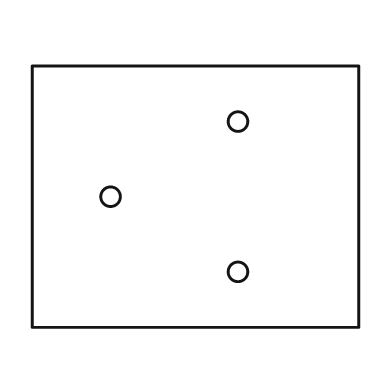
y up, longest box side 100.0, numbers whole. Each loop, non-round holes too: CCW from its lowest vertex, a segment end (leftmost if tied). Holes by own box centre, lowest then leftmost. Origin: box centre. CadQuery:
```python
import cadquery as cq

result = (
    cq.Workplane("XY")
    .moveTo(-50.0, -40.0)
    .lineTo(50.0, -40.0)
    .lineTo(50.0, 40.0)
    .lineTo(-50.0, 40.0)
    .close()
    .moveTo(13.0, -23.0)
    .circle(3.0)
    .moveTo(-26.0, 0.0)
    .circle(3.0)
    .moveTo(13.0, 23.0)
    .circle(3.0)
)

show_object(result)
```